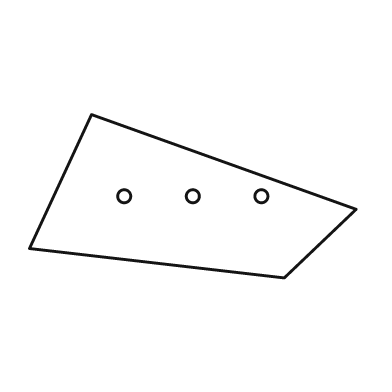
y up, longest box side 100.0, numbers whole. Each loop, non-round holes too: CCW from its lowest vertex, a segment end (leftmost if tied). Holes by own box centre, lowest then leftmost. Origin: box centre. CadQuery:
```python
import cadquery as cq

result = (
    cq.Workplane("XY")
    .moveTo(28.0, -25.0)
    .lineTo(50.0, -4.0)
    .lineTo(-31.0, 25.0)
    .lineTo(-50.0, -16.0)
    .close()
    .moveTo(-21.0, 0.0)
    .circle(2.0)
    .moveTo(0.0, 0.0)
    .circle(2.0)
    .moveTo(21.0, 0.0)
    .circle(2.0)
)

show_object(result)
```